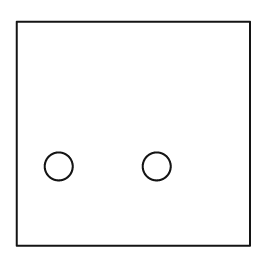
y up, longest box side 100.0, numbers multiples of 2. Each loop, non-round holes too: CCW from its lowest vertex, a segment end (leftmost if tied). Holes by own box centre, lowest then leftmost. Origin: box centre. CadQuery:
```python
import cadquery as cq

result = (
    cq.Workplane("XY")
    .moveTo(-50.0, -48.0)
    .lineTo(50.0, -48.0)
    .lineTo(50.0, 48.0)
    .lineTo(-50.0, 48.0)
    .close()
    .moveTo(-32.0, -14.0)
    .circle(6.0)
    .moveTo(10.0, -14.0)
    .circle(6.0)
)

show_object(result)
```